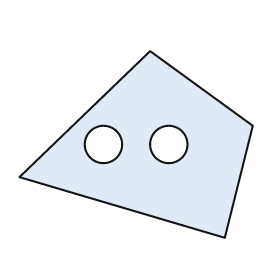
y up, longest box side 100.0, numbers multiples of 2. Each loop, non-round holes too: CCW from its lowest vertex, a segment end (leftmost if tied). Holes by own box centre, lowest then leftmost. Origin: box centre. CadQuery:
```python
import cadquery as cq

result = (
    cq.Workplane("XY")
    .moveTo(38.0, -40.0)
    .lineTo(50.0, 8.0)
    .lineTo(6.0, 40.0)
    .lineTo(-50.0, -14.0)
    .close()
    .moveTo(-14.0, 0.0)
    .circle(8.0)
    .moveTo(14.0, 0.0)
    .circle(8.0)
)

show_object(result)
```